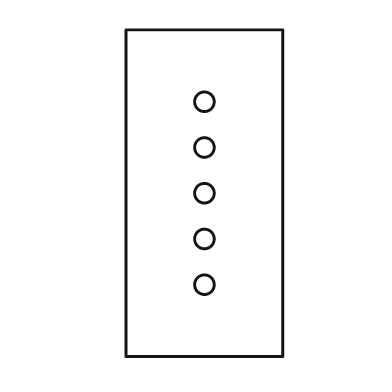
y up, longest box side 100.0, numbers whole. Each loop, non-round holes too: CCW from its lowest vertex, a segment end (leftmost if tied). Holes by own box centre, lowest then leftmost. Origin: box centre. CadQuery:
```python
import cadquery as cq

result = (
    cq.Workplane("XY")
    .moveTo(-24.0, -50.0)
    .lineTo(24.0, -50.0)
    .lineTo(24.0, 50.0)
    .lineTo(-24.0, 50.0)
    .close()
    .moveTo(0.0, -28.0)
    .circle(3.0)
    .moveTo(0.0, -14.0)
    .circle(3.0)
    .moveTo(0.0, 0.0)
    .circle(3.0)
    .moveTo(0.0, 14.0)
    .circle(3.0)
    .moveTo(0.0, 28.0)
    .circle(3.0)
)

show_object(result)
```